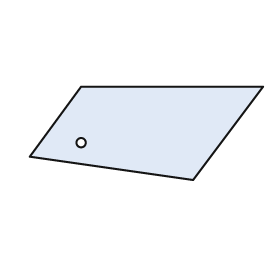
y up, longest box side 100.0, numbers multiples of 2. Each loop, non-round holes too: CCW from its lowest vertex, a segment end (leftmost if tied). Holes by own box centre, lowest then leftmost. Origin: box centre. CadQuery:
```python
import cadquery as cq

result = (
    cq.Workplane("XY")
    .moveTo(20.0, -20.0)
    .lineTo(50.0, 20.0)
    .lineTo(-28.0, 20.0)
    .lineTo(-50.0, -10.0)
    .close()
    .moveTo(-28.0, -4.0)
    .circle(2.0)
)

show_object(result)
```